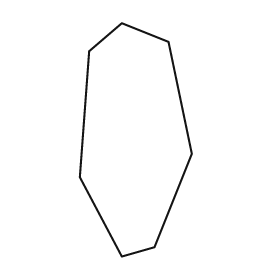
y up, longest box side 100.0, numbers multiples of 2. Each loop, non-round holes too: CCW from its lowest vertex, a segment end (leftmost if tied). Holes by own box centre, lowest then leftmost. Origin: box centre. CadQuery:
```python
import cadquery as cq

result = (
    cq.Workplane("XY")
    .moveTo(-6.0, -50.0)
    .lineTo(8.0, -46.0)
    .lineTo(24.0, -6.0)
    .lineTo(14.0, 42.0)
    .lineTo(-6.0, 50.0)
    .lineTo(-20.0, 38.0)
    .lineTo(-24.0, -16.0)
    .close()
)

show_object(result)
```